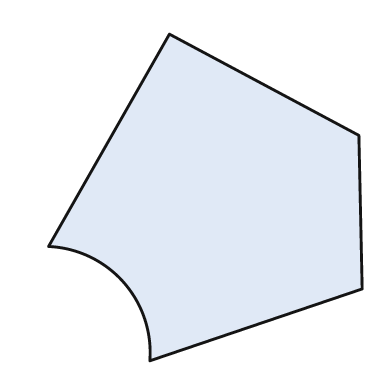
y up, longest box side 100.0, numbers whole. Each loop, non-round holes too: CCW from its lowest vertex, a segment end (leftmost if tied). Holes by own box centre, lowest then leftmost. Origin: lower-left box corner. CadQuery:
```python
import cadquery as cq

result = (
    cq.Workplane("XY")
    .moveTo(31.0, 0.0)
    .lineTo(96.0, 22.0)
    .lineTo(95.0, 69.0)
    .lineTo(37.0, 100.0)
    .lineTo(0.0, 35.0)
    .threePointArc((23.0, 24.0), (31.0, 0.0))
    .close()
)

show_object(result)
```